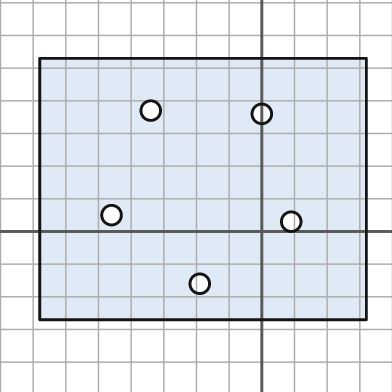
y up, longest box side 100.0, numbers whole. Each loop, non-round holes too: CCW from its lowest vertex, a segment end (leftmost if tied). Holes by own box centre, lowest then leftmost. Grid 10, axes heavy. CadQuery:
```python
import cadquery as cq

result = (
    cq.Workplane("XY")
    .moveTo(-68.0, -27.0)
    .lineTo(32.0, -27.0)
    .lineTo(32.0, 53.0)
    .lineTo(-68.0, 53.0)
    .close()
    .moveTo(-19.0, -16.0)
    .circle(3.0)
    .moveTo(9.0, 3.0)
    .circle(3.0)
    .moveTo(-46.0, 5.0)
    .circle(3.0)
    .moveTo(0.0, 36.0)
    .circle(3.0)
    .moveTo(-34.0, 37.0)
    .circle(3.0)
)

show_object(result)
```